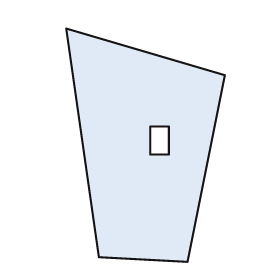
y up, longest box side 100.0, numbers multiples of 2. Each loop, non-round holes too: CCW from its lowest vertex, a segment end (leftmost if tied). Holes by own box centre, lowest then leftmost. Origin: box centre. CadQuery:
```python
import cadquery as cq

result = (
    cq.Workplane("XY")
    .moveTo(18.0, -50.0)
    .lineTo(34.0, 30.0)
    .lineTo(-34.0, 50.0)
    .lineTo(-20.0, -48.0)
    .close()
    .moveTo(2.0, -4.0)
    .lineTo(10.0, -4.0)
    .lineTo(10.0, 8.0)
    .lineTo(2.0, 8.0)
    .close()
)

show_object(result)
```